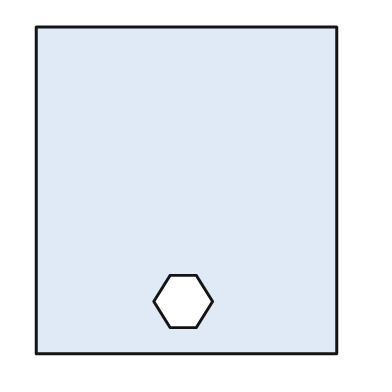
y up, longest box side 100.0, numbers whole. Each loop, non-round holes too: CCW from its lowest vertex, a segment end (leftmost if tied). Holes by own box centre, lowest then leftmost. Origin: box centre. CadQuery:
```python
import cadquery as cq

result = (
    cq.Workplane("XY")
    .moveTo(-46.0, -50.0)
    .lineTo(46.0, -50.0)
    .lineTo(46.0, 50.0)
    .lineTo(-46.0, 50.0)
    .close()
    .moveTo(-5.0, -42.0)
    .lineTo(3.0, -42.0)
    .lineTo(8.0, -34.0)
    .lineTo(3.0, -26.0)
    .lineTo(-5.0, -26.0)
    .lineTo(-10.0, -34.0)
    .close()
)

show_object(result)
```